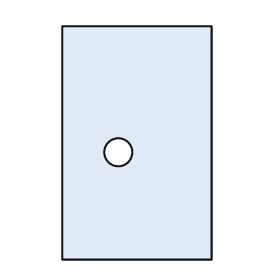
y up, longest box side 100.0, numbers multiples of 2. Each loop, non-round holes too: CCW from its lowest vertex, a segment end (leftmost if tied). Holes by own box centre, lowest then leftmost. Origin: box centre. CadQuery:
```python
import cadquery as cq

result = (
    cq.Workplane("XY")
    .moveTo(-32.0, -50.0)
    .lineTo(32.0, -50.0)
    .lineTo(32.0, 50.0)
    .lineTo(-32.0, 50.0)
    .close()
    .moveTo(-8.0, -4.0)
    .circle(6.0)
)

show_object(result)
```